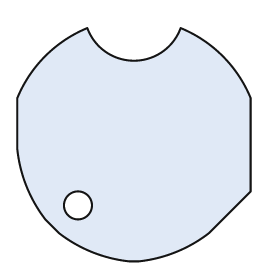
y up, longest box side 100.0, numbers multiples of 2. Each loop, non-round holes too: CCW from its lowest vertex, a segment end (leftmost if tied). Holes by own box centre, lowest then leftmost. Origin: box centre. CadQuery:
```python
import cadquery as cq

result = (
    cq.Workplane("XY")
    .moveTo(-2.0, -50.0)
    .lineTo(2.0, -50.0)
    .threePointArc((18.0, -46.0), (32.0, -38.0))
    .lineTo(50.0, -20.0)
    .lineTo(50.0, 20.0)
    .threePointArc((38.0, 38.0), (20.0, 50.0))
    .threePointArc((0.0, 36.0), (-20.0, 50.0))
    .threePointArc((-38.0, 38.0), (-50.0, 20.0))
    .lineTo(-50.0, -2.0)
    .threePointArc((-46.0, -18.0), (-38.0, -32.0))
    .lineTo(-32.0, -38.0)
    .threePointArc((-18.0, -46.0), (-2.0, -50.0))
    .close()
    .moveTo(-24.0, -26.0)
    .circle(6.0)
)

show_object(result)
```